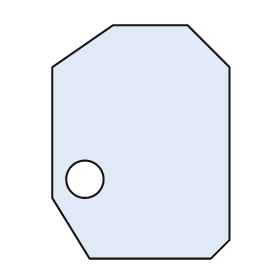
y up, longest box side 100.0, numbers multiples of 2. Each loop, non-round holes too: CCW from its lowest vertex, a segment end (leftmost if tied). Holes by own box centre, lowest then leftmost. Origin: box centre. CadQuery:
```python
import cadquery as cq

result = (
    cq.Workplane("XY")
    .moveTo(-22.0, -50.0)
    .lineTo(30.0, -50.0)
    .lineTo(38.0, -42.0)
    .lineTo(38.0, 32.0)
    .lineTo(20.0, 50.0)
    .lineTo(-12.0, 50.0)
    .lineTo(-38.0, 32.0)
    .lineTo(-38.0, -24.0)
    .close()
    .moveTo(-24.0, -16.0)
    .circle(8.0)
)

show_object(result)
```